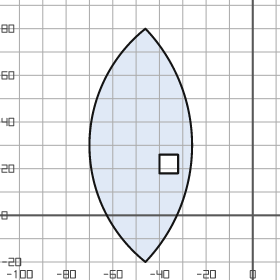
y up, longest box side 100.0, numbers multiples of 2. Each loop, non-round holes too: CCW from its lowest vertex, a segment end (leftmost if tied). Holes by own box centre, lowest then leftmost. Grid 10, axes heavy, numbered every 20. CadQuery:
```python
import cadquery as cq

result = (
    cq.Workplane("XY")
    .moveTo(-46.0, -20.0)
    .threePointArc((-26.0, 30.0), (-46.0, 80.0))
    .threePointArc((-70.0, 30.0), (-46.0, -20.0))
    .close()
    .moveTo(-40.0, 18.0)
    .lineTo(-32.0, 18.0)
    .lineTo(-32.0, 26.0)
    .lineTo(-40.0, 26.0)
    .close()
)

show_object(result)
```